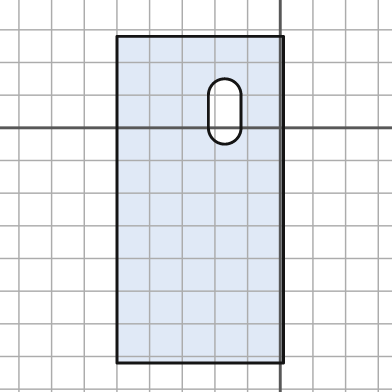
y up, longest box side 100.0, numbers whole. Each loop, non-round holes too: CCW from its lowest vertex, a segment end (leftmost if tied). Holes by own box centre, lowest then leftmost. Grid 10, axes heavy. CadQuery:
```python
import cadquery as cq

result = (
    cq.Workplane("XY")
    .moveTo(-50.0, -72.0)
    .lineTo(1.0, -72.0)
    .lineTo(1.0, 28.0)
    .lineTo(-50.0, 28.0)
    .close()
    .moveTo(-22.0, 0.0)
    .threePointArc((-17.0, -5.0), (-12.0, 0.0))
    .lineTo(-12.0, 10.0)
    .threePointArc((-17.0, 15.0), (-22.0, 10.0))
    .close()
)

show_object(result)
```